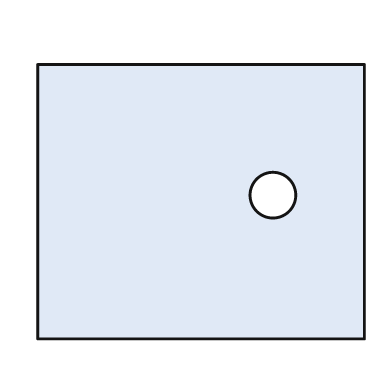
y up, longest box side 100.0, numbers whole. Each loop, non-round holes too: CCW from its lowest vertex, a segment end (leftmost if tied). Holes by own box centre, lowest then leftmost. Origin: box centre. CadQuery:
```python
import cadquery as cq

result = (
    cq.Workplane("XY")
    .moveTo(-50.0, -42.0)
    .lineTo(50.0, -42.0)
    .lineTo(50.0, 42.0)
    .lineTo(-50.0, 42.0)
    .close()
    .moveTo(22.0, 2.0)
    .circle(7.0)
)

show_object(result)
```